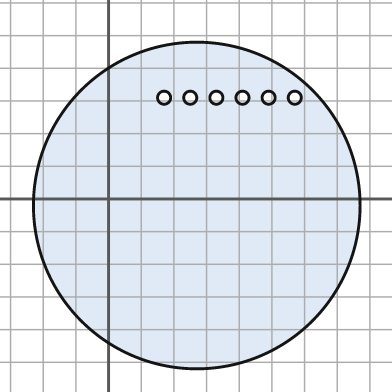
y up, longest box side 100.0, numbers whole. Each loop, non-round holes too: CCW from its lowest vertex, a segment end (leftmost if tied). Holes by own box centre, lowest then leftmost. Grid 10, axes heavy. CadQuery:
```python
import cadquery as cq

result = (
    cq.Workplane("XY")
    .moveTo(27.0, -2.0)
    .circle(50.0)
    .moveTo(17.0, 31.0)
    .circle(2.0)
    .moveTo(25.0, 31.0)
    .circle(2.0)
    .moveTo(33.0, 31.0)
    .circle(2.0)
    .moveTo(41.0, 31.0)
    .circle(2.0)
    .moveTo(49.0, 31.0)
    .circle(2.0)
    .moveTo(57.0, 31.0)
    .circle(2.0)
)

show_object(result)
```